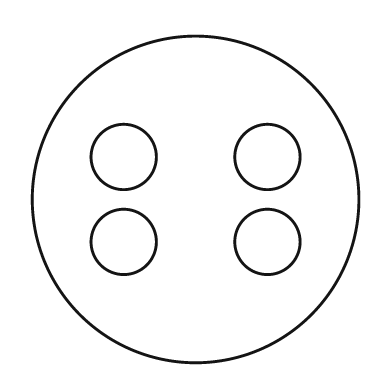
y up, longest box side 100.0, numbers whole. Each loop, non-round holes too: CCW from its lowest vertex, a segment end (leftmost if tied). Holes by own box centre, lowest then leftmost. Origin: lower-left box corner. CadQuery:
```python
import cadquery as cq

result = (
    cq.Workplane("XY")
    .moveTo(50.0, 50.0)
    .circle(50.0)
    .moveTo(28.0, 37.0)
    .circle(10.0)
    .moveTo(72.0, 37.0)
    .circle(10.0)
    .moveTo(28.0, 63.0)
    .circle(10.0)
    .moveTo(72.0, 63.0)
    .circle(10.0)
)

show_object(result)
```